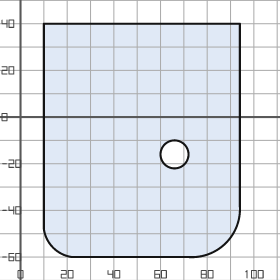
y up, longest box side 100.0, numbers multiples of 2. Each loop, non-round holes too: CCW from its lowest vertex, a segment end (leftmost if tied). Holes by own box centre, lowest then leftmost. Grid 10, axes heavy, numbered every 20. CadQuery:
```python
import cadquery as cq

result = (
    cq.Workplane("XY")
    .moveTo(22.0, -60.0)
    .lineTo(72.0, -60.0)
    .threePointArc((88.0, -54.0), (94.0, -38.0))
    .lineTo(94.0, 40.0)
    .lineTo(10.0, 40.0)
    .lineTo(10.0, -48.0)
    .threePointArc((14.0, -56.0), (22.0, -60.0))
    .close()
    .moveTo(66.0, -16.0)
    .circle(6.0)
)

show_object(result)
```